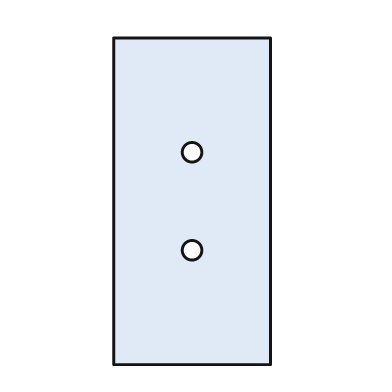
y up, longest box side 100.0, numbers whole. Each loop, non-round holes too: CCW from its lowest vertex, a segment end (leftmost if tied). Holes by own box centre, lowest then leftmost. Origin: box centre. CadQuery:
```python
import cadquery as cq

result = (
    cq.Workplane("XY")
    .moveTo(-24.0, -50.0)
    .lineTo(24.0, -50.0)
    .lineTo(24.0, 50.0)
    .lineTo(-24.0, 50.0)
    .close()
    .moveTo(0.0, -15.0)
    .circle(3.0)
    .moveTo(0.0, 15.0)
    .circle(3.0)
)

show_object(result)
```